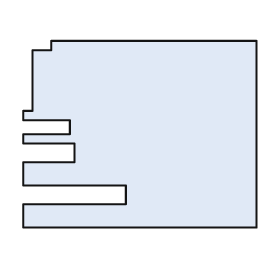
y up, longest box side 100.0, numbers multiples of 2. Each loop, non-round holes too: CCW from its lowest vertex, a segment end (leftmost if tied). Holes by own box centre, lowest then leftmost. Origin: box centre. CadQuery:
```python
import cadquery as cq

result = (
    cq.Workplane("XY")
    .moveTo(-50.0, -40.0)
    .lineTo(50.0, -40.0)
    .lineTo(50.0, 40.0)
    .lineTo(-38.0, 40.0)
    .lineTo(-38.0, 36.0)
    .lineTo(-46.0, 36.0)
    .lineTo(-46.0, 10.0)
    .lineTo(-50.0, 10.0)
    .lineTo(-50.0, 6.0)
    .lineTo(-30.0, 6.0)
    .lineTo(-30.0, 0.0)
    .lineTo(-50.0, 0.0)
    .lineTo(-50.0, -4.0)
    .lineTo(-28.0, -4.0)
    .lineTo(-28.0, -12.0)
    .lineTo(-50.0, -12.0)
    .lineTo(-50.0, -22.0)
    .lineTo(-6.0, -22.0)
    .lineTo(-6.0, -30.0)
    .lineTo(-50.0, -30.0)
    .close()
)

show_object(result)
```